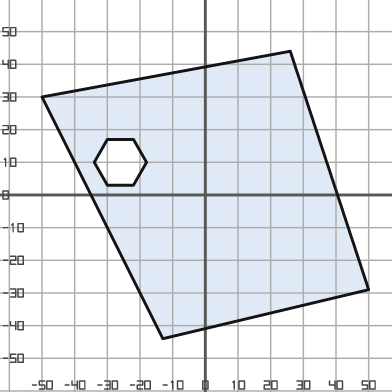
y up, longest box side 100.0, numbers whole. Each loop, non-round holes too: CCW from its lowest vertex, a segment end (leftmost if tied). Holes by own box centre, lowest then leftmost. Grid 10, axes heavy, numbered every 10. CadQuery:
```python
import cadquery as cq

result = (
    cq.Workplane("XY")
    .moveTo(-13.0, -44.0)
    .lineTo(50.0, -29.0)
    .lineTo(26.0, 44.0)
    .lineTo(-50.0, 30.0)
    .close()
    .moveTo(-30.0, 3.0)
    .lineTo(-22.0, 3.0)
    .lineTo(-18.0, 10.0)
    .lineTo(-22.0, 17.0)
    .lineTo(-30.0, 17.0)
    .lineTo(-34.0, 10.0)
    .close()
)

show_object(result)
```